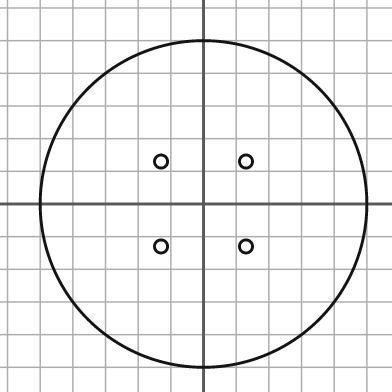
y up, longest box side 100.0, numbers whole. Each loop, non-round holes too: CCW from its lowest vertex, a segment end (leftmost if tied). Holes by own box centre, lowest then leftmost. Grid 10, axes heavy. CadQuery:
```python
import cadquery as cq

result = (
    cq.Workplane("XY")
    .moveTo(0.0, 0.0)
    .circle(50.0)
    .moveTo(-13.0, -13.0)
    .circle(2.0)
    .moveTo(13.0, -13.0)
    .circle(2.0)
    .moveTo(-13.0, 13.0)
    .circle(2.0)
    .moveTo(13.0, 13.0)
    .circle(2.0)
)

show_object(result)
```